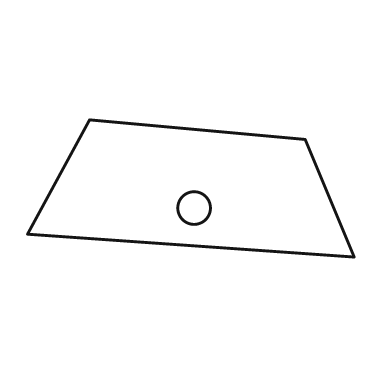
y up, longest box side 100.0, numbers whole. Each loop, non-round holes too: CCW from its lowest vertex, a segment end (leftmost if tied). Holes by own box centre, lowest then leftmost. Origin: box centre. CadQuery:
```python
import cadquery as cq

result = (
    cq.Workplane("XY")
    .moveTo(50.0, -21.0)
    .lineTo(35.0, 15.0)
    .lineTo(-31.0, 21.0)
    .lineTo(-50.0, -14.0)
    .close()
    .moveTo(1.0, -6.0)
    .circle(5.0)
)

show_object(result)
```